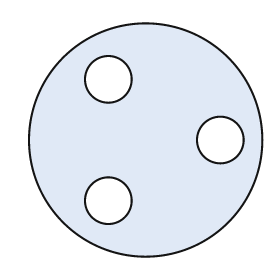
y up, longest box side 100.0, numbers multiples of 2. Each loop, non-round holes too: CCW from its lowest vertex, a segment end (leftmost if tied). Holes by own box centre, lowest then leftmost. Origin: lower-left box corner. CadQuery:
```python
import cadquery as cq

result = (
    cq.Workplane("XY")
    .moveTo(50.0, 50.0)
    .circle(50.0)
    .moveTo(34.0, 24.0)
    .circle(10.0)
    .moveTo(82.0, 50.0)
    .circle(10.0)
    .moveTo(34.0, 76.0)
    .circle(10.0)
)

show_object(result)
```